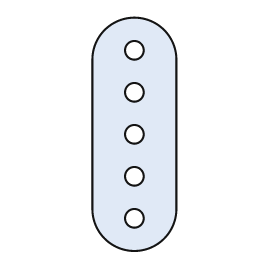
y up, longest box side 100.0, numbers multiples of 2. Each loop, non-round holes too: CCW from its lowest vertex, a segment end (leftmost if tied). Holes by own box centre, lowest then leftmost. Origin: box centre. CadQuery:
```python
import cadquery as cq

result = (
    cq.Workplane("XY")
    .moveTo(-18.0, -32.0)
    .threePointArc((0.0, -50.0), (18.0, -32.0))
    .lineTo(18.0, 32.0)
    .threePointArc((0.0, 50.0), (-18.0, 32.0))
    .close()
    .moveTo(0.0, -36.0)
    .circle(4.0)
    .moveTo(0.0, -18.0)
    .circle(4.0)
    .moveTo(0.0, 0.0)
    .circle(4.0)
    .moveTo(0.0, 18.0)
    .circle(4.0)
    .moveTo(0.0, 36.0)
    .circle(4.0)
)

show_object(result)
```